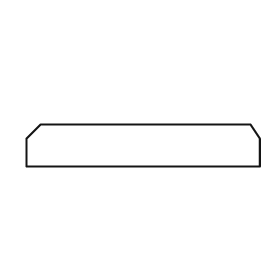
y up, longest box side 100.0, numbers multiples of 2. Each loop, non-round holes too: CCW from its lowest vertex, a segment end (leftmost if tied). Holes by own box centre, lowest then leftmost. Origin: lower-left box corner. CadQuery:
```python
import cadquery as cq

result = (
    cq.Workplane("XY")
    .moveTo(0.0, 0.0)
    .lineTo(100.0, 0.0)
    .lineTo(100.0, 12.0)
    .lineTo(96.0, 18.0)
    .lineTo(6.0, 18.0)
    .lineTo(0.0, 12.0)
    .close()
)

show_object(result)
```